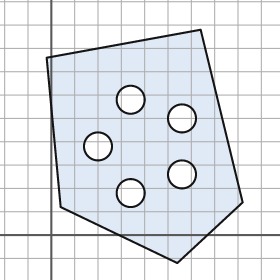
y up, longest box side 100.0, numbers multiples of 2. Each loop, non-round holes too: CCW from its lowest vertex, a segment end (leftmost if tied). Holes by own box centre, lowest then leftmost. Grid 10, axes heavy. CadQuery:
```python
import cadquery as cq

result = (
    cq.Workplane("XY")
    .moveTo(54.0, -12.0)
    .lineTo(82.0, 14.0)
    .lineTo(64.0, 88.0)
    .lineTo(-2.0, 76.0)
    .lineTo(4.0, 12.0)
    .close()
    .moveTo(34.0, 18.0)
    .circle(6.0)
    .moveTo(56.0, 26.0)
    .circle(6.0)
    .moveTo(20.0, 38.0)
    .circle(6.0)
    .moveTo(56.0, 50.0)
    .circle(6.0)
    .moveTo(34.0, 58.0)
    .circle(6.0)
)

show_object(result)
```